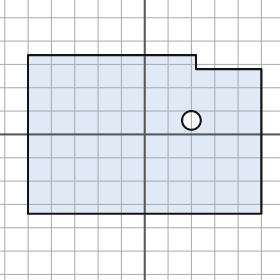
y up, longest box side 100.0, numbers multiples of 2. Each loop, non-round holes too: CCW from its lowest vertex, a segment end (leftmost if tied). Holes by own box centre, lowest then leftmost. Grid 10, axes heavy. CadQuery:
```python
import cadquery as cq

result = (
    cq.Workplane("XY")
    .moveTo(-50.0, -34.0)
    .lineTo(50.0, -34.0)
    .lineTo(50.0, 28.0)
    .lineTo(22.0, 28.0)
    .lineTo(22.0, 34.0)
    .lineTo(-50.0, 34.0)
    .close()
    .moveTo(20.0, 6.0)
    .circle(4.0)
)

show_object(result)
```